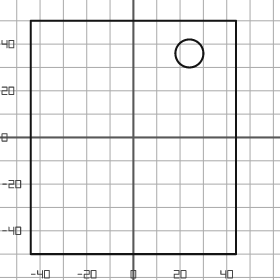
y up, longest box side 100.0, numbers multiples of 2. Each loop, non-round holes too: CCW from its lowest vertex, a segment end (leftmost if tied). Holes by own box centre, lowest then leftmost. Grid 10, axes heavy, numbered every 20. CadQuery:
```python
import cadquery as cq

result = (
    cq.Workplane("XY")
    .moveTo(-44.0, -50.0)
    .lineTo(44.0, -50.0)
    .lineTo(44.0, 50.0)
    .lineTo(-44.0, 50.0)
    .close()
    .moveTo(24.0, 36.0)
    .circle(6.0)
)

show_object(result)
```